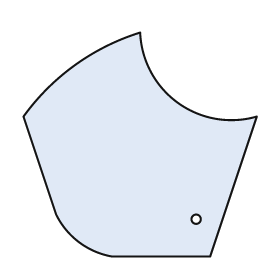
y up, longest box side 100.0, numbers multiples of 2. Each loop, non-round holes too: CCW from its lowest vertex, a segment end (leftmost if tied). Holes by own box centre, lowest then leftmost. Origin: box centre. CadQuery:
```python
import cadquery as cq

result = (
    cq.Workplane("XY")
    .moveTo(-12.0, -48.0)
    .lineTo(30.0, -48.0)
    .lineTo(50.0, 12.0)
    .threePointArc((16.0, 18.0), (0.0, 48.0))
    .threePointArc((-28.0, 34.0), (-50.0, 12.0))
    .lineTo(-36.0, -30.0)
    .threePointArc((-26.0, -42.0), (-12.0, -48.0))
    .close()
    .moveTo(24.0, -32.0)
    .circle(2.0)
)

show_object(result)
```